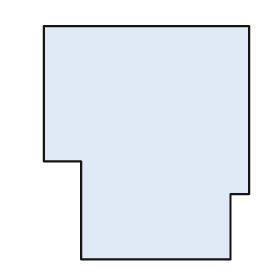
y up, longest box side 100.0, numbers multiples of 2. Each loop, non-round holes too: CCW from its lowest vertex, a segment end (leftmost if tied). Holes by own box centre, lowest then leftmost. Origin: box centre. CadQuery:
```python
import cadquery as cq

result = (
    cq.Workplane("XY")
    .moveTo(-28.0, -50.0)
    .lineTo(36.0, -50.0)
    .lineTo(36.0, -22.0)
    .lineTo(44.0, -22.0)
    .lineTo(44.0, 50.0)
    .lineTo(-44.0, 50.0)
    .lineTo(-44.0, -8.0)
    .lineTo(-28.0, -8.0)
    .close()
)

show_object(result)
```